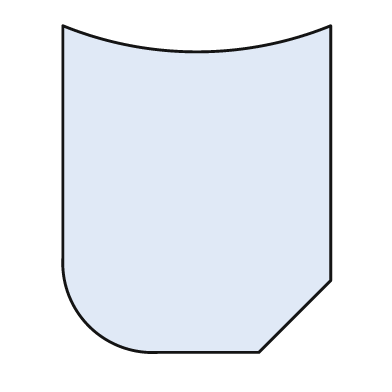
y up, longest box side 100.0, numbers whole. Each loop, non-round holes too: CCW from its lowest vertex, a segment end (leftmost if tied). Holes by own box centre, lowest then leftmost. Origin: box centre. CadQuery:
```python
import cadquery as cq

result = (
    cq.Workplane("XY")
    .moveTo(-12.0, -50.0)
    .lineTo(19.0, -50.0)
    .lineTo(41.0, -28.0)
    .lineTo(41.0, 50.0)
    .threePointArc((0.0, 42.0), (-41.0, 50.0))
    .lineTo(-41.0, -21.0)
    .threePointArc((-33.0, -42.0), (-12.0, -50.0))
    .close()
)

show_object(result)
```